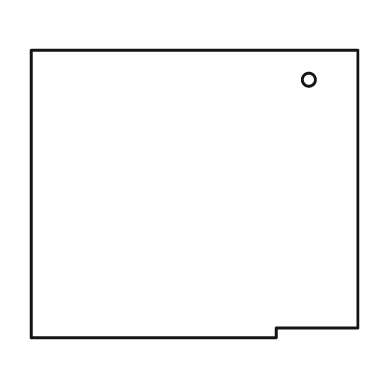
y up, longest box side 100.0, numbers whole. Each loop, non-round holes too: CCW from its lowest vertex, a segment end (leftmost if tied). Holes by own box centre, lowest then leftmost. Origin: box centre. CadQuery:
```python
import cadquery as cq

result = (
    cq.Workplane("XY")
    .moveTo(-50.0, -44.0)
    .lineTo(25.0, -44.0)
    .lineTo(25.0, -41.0)
    .lineTo(50.0, -41.0)
    .lineTo(50.0, 44.0)
    .lineTo(-50.0, 44.0)
    .close()
    .moveTo(35.0, 35.0)
    .circle(2.0)
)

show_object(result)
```